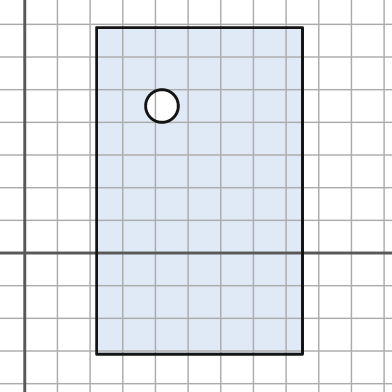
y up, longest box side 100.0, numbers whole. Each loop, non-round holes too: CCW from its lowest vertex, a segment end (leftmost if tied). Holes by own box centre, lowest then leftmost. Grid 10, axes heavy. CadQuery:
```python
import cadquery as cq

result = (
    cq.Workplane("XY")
    .moveTo(22.0, -31.0)
    .lineTo(85.0, -31.0)
    .lineTo(85.0, 69.0)
    .lineTo(22.0, 69.0)
    .close()
    .moveTo(42.0, 45.0)
    .circle(5.0)
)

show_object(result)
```